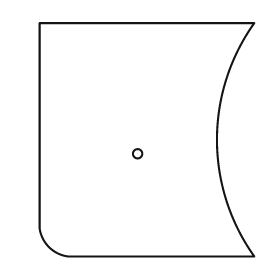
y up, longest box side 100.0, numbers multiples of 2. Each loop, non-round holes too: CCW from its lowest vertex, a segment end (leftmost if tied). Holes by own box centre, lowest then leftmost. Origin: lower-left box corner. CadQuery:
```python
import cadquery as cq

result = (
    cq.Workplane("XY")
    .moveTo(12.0, 0.0)
    .lineTo(92.0, 0.0)
    .threePointArc((76.0, 50.0), (92.0, 100.0))
    .lineTo(0.0, 100.0)
    .lineTo(0.0, 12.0)
    .threePointArc((4.0, 4.0), (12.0, 0.0))
    .close()
    .moveTo(42.0, 44.0)
    .circle(2.0)
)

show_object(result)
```